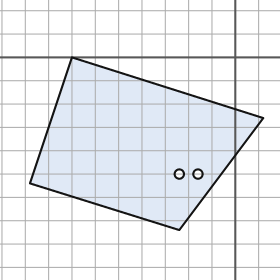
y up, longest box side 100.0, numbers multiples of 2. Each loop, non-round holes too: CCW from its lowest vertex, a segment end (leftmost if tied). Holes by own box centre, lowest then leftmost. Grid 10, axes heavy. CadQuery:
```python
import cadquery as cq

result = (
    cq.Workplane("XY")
    .moveTo(-24.0, -74.0)
    .lineTo(12.0, -26.0)
    .lineTo(-70.0, 0.0)
    .lineTo(-88.0, -54.0)
    .close()
    .moveTo(-24.0, -50.0)
    .circle(2.0)
    .moveTo(-16.0, -50.0)
    .circle(2.0)
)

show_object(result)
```